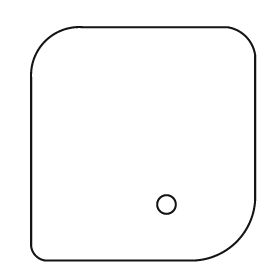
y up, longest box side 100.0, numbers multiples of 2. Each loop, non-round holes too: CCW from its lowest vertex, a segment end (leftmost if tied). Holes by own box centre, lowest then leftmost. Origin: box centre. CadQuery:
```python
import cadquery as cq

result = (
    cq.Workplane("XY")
    .moveTo(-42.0, -50.0)
    .lineTo(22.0, -50.0)
    .threePointArc((40.0, -42.0), (48.0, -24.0))
    .lineTo(48.0, 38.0)
    .threePointArc((44.0, 46.0), (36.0, 50.0))
    .lineTo(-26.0, 50.0)
    .threePointArc((-42.0, 44.0), (-48.0, 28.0))
    .lineTo(-48.0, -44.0)
    .threePointArc((-46.0, -48.0), (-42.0, -50.0))
    .close()
    .moveTo(10.0, -26.0)
    .circle(4.0)
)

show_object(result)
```